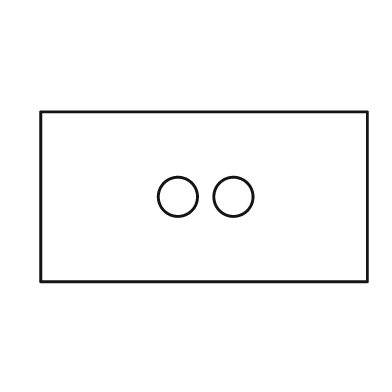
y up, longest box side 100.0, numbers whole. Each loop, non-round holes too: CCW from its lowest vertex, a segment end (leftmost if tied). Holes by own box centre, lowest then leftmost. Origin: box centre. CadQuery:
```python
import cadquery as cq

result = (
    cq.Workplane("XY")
    .moveTo(-50.0, -26.0)
    .lineTo(50.0, -26.0)
    .lineTo(50.0, 26.0)
    .lineTo(-50.0, 26.0)
    .close()
    .moveTo(-8.0, 0.0)
    .circle(6.0)
    .moveTo(9.0, 0.0)
    .circle(6.0)
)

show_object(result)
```